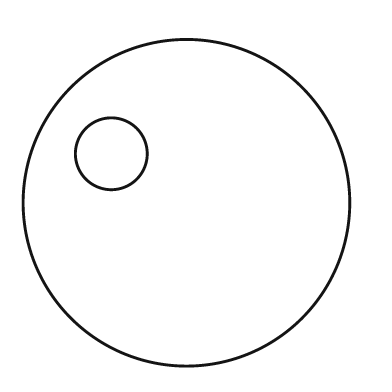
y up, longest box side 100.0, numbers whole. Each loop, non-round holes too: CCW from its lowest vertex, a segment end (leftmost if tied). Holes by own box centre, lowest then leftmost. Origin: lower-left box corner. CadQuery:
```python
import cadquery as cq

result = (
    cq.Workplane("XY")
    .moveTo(50.0, 50.0)
    .circle(50.0)
    .moveTo(27.0, 65.0)
    .circle(11.0)
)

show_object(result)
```